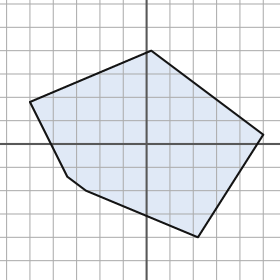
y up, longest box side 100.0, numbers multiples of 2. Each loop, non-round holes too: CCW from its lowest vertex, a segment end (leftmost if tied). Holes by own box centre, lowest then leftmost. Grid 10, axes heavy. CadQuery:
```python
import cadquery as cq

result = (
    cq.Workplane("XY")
    .moveTo(22.0, -40.0)
    .lineTo(50.0, 4.0)
    .lineTo(2.0, 40.0)
    .lineTo(-50.0, 18.0)
    .lineTo(-34.0, -14.0)
    .lineTo(-26.0, -20.0)
    .close()
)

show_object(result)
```